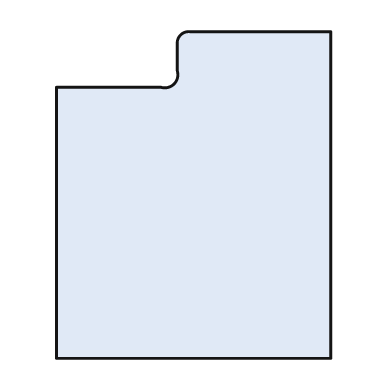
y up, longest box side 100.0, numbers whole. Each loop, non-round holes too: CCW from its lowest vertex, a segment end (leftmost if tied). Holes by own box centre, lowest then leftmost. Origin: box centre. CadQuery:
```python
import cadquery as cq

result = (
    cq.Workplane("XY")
    .moveTo(-42.0, -50.0)
    .lineTo(42.0, -50.0)
    .lineTo(42.0, 50.0)
    .lineTo(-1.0, 50.0)
    .threePointArc((-4.0, 49.0), (-5.0, 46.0))
    .lineTo(-5.0, 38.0)
    .threePointArc((-6.0, 34.0), (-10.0, 33.0))
    .lineTo(-42.0, 33.0)
    .close()
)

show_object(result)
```